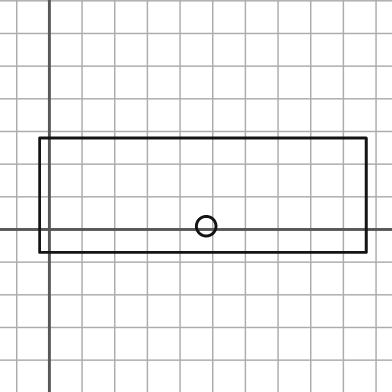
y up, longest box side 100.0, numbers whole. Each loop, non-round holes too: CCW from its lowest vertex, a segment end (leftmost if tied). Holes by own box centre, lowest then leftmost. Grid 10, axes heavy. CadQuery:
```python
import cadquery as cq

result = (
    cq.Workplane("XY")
    .moveTo(-3.0, -7.0)
    .lineTo(97.0, -7.0)
    .lineTo(97.0, 28.0)
    .lineTo(-3.0, 28.0)
    .close()
    .moveTo(48.0, 1.0)
    .circle(3.0)
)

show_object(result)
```